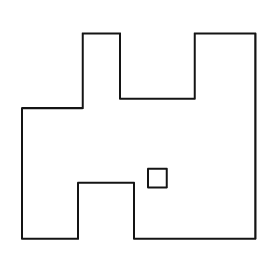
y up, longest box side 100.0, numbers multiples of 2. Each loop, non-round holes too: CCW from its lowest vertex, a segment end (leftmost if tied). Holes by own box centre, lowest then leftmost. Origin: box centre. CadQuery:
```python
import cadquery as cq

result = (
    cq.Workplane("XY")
    .moveTo(-50.0, -44.0)
    .lineTo(-26.0, -44.0)
    .lineTo(-26.0, -20.0)
    .lineTo(-2.0, -20.0)
    .lineTo(-2.0, -44.0)
    .lineTo(50.0, -44.0)
    .lineTo(50.0, 44.0)
    .lineTo(24.0, 44.0)
    .lineTo(24.0, 16.0)
    .lineTo(-8.0, 16.0)
    .lineTo(-8.0, 44.0)
    .lineTo(-24.0, 44.0)
    .lineTo(-24.0, 12.0)
    .lineTo(-50.0, 12.0)
    .close()
    .moveTo(4.0, -22.0)
    .lineTo(12.0, -22.0)
    .lineTo(12.0, -14.0)
    .lineTo(4.0, -14.0)
    .close()
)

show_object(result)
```